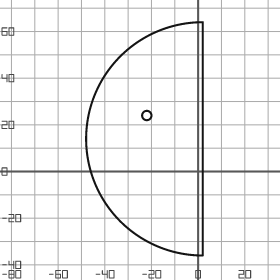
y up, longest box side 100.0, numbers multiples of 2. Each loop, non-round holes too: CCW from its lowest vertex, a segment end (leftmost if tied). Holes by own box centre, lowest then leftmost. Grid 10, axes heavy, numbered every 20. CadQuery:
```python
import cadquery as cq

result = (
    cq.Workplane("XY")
    .moveTo(2.0, -36.0)
    .lineTo(2.0, 64.0)
    .threePointArc((-48.0, 14.0), (2.0, -36.0))
    .close()
    .moveTo(-22.0, 24.0)
    .circle(2.0)
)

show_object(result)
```